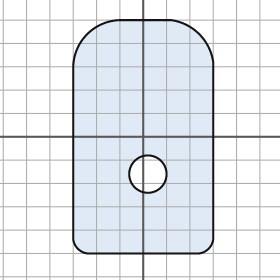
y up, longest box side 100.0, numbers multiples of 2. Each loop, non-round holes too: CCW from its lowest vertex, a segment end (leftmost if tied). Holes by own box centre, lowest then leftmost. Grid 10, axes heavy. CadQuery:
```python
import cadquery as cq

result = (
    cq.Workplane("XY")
    .moveTo(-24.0, -50.0)
    .lineTo(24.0, -50.0)
    .threePointArc((28.0, -48.0), (30.0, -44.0))
    .lineTo(30.0, 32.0)
    .threePointArc((24.0, 44.0), (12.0, 50.0))
    .lineTo(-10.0, 50.0)
    .threePointArc((-24.0, 44.0), (-30.0, 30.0))
    .lineTo(-30.0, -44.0)
    .threePointArc((-28.0, -48.0), (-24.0, -50.0))
    .close()
    .moveTo(2.0, -16.0)
    .circle(8.0)
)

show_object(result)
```